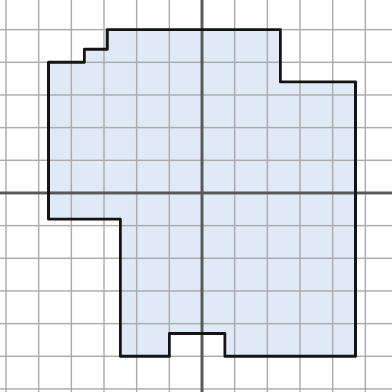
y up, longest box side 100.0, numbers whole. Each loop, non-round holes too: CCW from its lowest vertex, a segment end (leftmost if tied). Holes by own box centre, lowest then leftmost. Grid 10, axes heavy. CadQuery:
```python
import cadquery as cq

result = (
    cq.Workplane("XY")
    .moveTo(-25.0, -50.0)
    .lineTo(-10.0, -50.0)
    .lineTo(-10.0, -43.0)
    .lineTo(7.0, -43.0)
    .lineTo(7.0, -50.0)
    .lineTo(47.0, -50.0)
    .lineTo(47.0, 34.0)
    .lineTo(24.0, 34.0)
    .lineTo(24.0, 50.0)
    .lineTo(-29.0, 50.0)
    .lineTo(-29.0, 44.0)
    .lineTo(-36.0, 44.0)
    .lineTo(-36.0, 40.0)
    .lineTo(-47.0, 40.0)
    .lineTo(-47.0, -8.0)
    .lineTo(-25.0, -8.0)
    .close()
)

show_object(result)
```